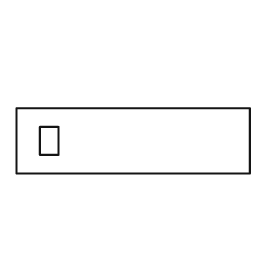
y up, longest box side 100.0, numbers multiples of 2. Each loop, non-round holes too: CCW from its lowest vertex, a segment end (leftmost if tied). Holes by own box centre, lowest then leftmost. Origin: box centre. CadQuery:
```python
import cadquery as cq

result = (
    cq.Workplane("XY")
    .moveTo(-50.0, -14.0)
    .lineTo(50.0, -14.0)
    .lineTo(50.0, 14.0)
    .lineTo(-50.0, 14.0)
    .close()
    .moveTo(-40.0, -6.0)
    .lineTo(-32.0, -6.0)
    .lineTo(-32.0, 6.0)
    .lineTo(-40.0, 6.0)
    .close()
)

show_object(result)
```